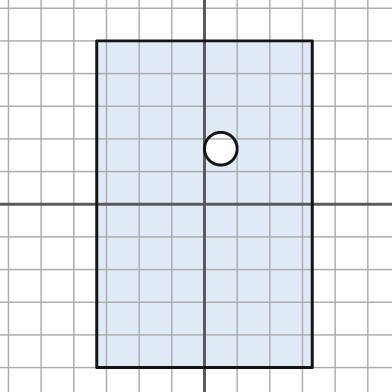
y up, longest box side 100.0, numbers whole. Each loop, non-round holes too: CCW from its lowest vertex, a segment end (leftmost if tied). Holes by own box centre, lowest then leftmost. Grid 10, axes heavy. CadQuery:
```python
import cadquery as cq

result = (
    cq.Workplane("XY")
    .moveTo(-33.0, -50.0)
    .lineTo(33.0, -50.0)
    .lineTo(33.0, 50.0)
    .lineTo(-33.0, 50.0)
    .close()
    .moveTo(5.0, 17.0)
    .circle(5.0)
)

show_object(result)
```